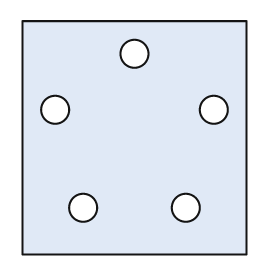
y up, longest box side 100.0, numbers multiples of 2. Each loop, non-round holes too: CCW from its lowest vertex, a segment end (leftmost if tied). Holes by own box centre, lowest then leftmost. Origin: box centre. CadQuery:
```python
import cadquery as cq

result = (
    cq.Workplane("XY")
    .moveTo(-48.0, -50.0)
    .lineTo(48.0, -50.0)
    .lineTo(48.0, 50.0)
    .lineTo(-48.0, 50.0)
    .close()
    .moveTo(-22.0, -30.0)
    .circle(6.0)
    .moveTo(22.0, -30.0)
    .circle(6.0)
    .moveTo(-34.0, 12.0)
    .circle(6.0)
    .moveTo(34.0, 12.0)
    .circle(6.0)
    .moveTo(0.0, 36.0)
    .circle(6.0)
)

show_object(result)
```